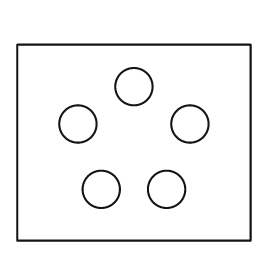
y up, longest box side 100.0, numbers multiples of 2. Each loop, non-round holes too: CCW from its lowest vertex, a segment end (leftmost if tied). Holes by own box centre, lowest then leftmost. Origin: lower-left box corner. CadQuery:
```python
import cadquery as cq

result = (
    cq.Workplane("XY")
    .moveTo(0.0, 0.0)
    .lineTo(100.0, 0.0)
    .lineTo(100.0, 84.0)
    .lineTo(0.0, 84.0)
    .close()
    .moveTo(36.0, 22.0)
    .circle(8.0)
    .moveTo(64.0, 22.0)
    .circle(8.0)
    .moveTo(26.0, 50.0)
    .circle(8.0)
    .moveTo(74.0, 50.0)
    .circle(8.0)
    .moveTo(50.0, 66.0)
    .circle(8.0)
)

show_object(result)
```